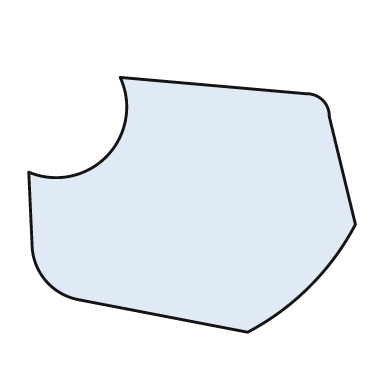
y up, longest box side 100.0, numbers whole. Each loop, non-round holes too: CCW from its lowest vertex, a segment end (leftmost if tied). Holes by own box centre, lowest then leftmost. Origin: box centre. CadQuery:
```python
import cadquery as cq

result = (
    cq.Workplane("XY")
    .moveTo(17.0, -39.0)
    .threePointArc((36.0, -25.0), (50.0, -6.0))
    .lineTo(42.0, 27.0)
    .threePointArc((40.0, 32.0), (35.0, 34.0))
    .lineTo(-22.0, 39.0)
    .threePointArc((-26.0, 15.0), (-50.0, 10.0))
    .lineTo(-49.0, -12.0)
    .threePointArc((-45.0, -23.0), (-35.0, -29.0))
    .close()
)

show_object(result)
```